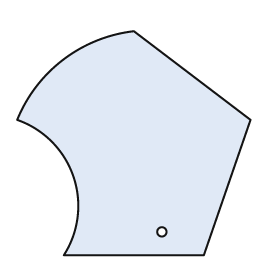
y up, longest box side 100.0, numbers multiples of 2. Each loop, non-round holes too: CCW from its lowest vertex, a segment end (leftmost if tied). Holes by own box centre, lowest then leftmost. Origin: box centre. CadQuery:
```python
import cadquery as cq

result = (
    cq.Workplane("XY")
    .moveTo(-30.0, -48.0)
    .lineTo(30.0, -48.0)
    .lineTo(50.0, 10.0)
    .lineTo(0.0, 48.0)
    .threePointArc((-30.0, 36.0), (-50.0, 10.0))
    .threePointArc((-26.0, -14.0), (-30.0, -48.0))
    .close()
    .moveTo(12.0, -38.0)
    .circle(2.0)
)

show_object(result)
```